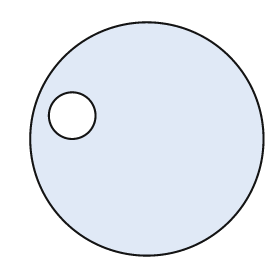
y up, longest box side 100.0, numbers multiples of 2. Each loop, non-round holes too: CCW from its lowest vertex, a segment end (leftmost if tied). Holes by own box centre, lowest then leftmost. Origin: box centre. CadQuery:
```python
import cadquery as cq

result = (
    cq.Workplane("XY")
    .moveTo(0.0, 0.0)
    .circle(50.0)
    .moveTo(-32.0, 10.0)
    .circle(10.0)
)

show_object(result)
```